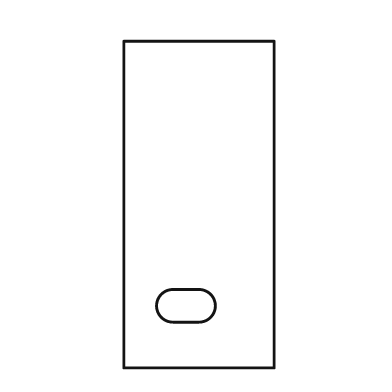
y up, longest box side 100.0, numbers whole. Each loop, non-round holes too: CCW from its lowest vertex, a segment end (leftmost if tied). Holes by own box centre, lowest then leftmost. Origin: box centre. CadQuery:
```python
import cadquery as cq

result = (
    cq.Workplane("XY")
    .moveTo(-23.0, -50.0)
    .lineTo(23.0, -50.0)
    .lineTo(23.0, 50.0)
    .lineTo(-23.0, 50.0)
    .close()
    .moveTo(-8.0, -36.0)
    .lineTo(0.0, -36.0)
    .threePointArc((5.0, -31.0), (0.0, -26.0))
    .lineTo(-8.0, -26.0)
    .threePointArc((-13.0, -31.0), (-8.0, -36.0))
    .close()
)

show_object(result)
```